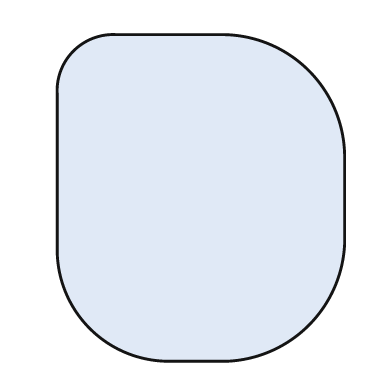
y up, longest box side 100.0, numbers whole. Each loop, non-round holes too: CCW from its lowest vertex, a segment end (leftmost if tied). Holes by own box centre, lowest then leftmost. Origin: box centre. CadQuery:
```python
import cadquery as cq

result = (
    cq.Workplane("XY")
    .moveTo(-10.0, -50.0)
    .lineTo(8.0, -50.0)
    .threePointArc((33.0, -39.0), (44.0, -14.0))
    .lineTo(44.0, 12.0)
    .threePointArc((33.0, 39.0), (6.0, 50.0))
    .lineTo(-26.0, 50.0)
    .threePointArc((-39.0, 45.0), (-44.0, 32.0))
    .lineTo(-44.0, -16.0)
    .threePointArc((-34.0, -40.0), (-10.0, -50.0))
    .close()
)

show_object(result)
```